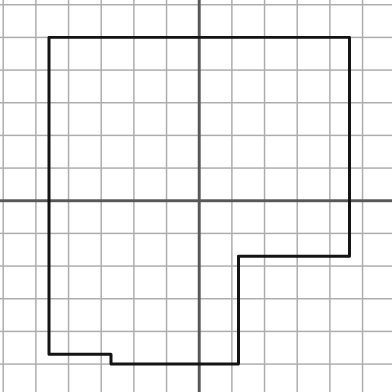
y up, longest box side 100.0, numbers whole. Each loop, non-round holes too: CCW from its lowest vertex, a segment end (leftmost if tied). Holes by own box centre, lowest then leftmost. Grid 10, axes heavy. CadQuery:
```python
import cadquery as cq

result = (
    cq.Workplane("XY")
    .moveTo(-27.0, -50.0)
    .lineTo(12.0, -50.0)
    .lineTo(12.0, -17.0)
    .lineTo(46.0, -17.0)
    .lineTo(46.0, 50.0)
    .lineTo(-46.0, 50.0)
    .lineTo(-46.0, -47.0)
    .lineTo(-27.0, -47.0)
    .close()
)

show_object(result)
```